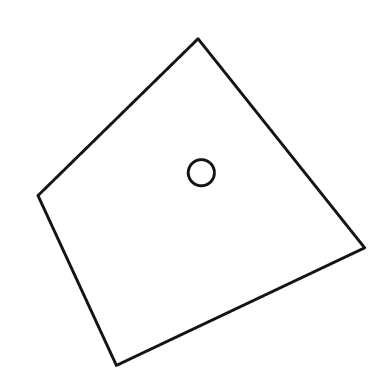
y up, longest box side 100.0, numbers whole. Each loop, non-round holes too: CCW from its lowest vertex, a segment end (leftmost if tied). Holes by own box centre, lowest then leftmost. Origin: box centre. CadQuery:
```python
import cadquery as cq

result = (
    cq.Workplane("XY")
    .moveTo(-26.0, -50.0)
    .lineTo(50.0, -14.0)
    .lineTo(-1.0, 50.0)
    .lineTo(-50.0, 2.0)
    .close()
    .moveTo(0.0, 9.0)
    .circle(4.0)
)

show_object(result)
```